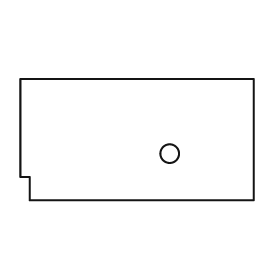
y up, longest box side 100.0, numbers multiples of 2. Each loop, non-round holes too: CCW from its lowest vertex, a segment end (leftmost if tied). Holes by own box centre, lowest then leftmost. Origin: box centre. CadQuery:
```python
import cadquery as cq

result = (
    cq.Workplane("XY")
    .moveTo(-46.0, -26.0)
    .lineTo(50.0, -26.0)
    .lineTo(50.0, 26.0)
    .lineTo(-50.0, 26.0)
    .lineTo(-50.0, -16.0)
    .lineTo(-46.0, -16.0)
    .close()
    .moveTo(14.0, -6.0)
    .circle(4.0)
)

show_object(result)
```